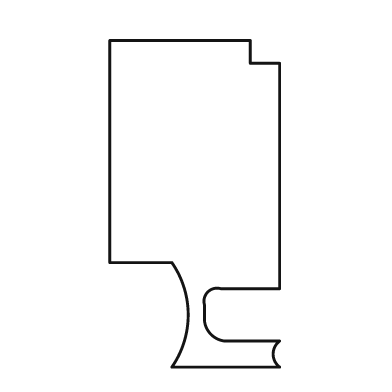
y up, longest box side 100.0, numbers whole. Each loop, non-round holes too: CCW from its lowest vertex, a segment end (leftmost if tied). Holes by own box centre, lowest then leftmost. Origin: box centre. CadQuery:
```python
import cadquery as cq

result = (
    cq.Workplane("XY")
    .moveTo(-7.0, -50.0)
    .lineTo(26.0, -50.0)
    .threePointArc((24.0, -46.0), (26.0, -42.0))
    .lineTo(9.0, -42.0)
    .threePointArc((5.0, -40.0), (3.0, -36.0))
    .lineTo(3.0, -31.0)
    .threePointArc((4.0, -27.0), (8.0, -26.0))
    .lineTo(26.0, -26.0)
    .lineTo(26.0, 43.0)
    .lineTo(17.0, 43.0)
    .lineTo(17.0, 50.0)
    .lineTo(-26.0, 50.0)
    .lineTo(-26.0, -18.0)
    .lineTo(-7.0, -18.0)
    .threePointArc((-2.0, -34.0), (-7.0, -50.0))
    .close()
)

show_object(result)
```